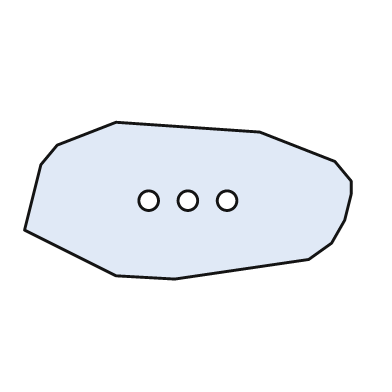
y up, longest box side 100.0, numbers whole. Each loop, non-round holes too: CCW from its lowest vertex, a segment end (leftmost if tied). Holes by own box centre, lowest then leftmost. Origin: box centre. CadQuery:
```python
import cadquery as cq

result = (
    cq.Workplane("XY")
    .moveTo(-4.0, -24.0)
    .lineTo(37.0, -18.0)
    .lineTo(44.0, -13.0)
    .lineTo(48.0, -6.0)
    .lineTo(50.0, 2.0)
    .lineTo(50.0, 6.0)
    .lineTo(45.0, 12.0)
    .lineTo(22.0, 21.0)
    .lineTo(-22.0, 24.0)
    .lineTo(-40.0, 17.0)
    .lineTo(-45.0, 11.0)
    .lineTo(-50.0, -9.0)
    .lineTo(-22.0, -23.0)
    .close()
    .moveTo(-12.0, 0.0)
    .circle(3.0)
    .moveTo(0.0, 0.0)
    .circle(3.0)
    .moveTo(12.0, 0.0)
    .circle(3.0)
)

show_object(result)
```